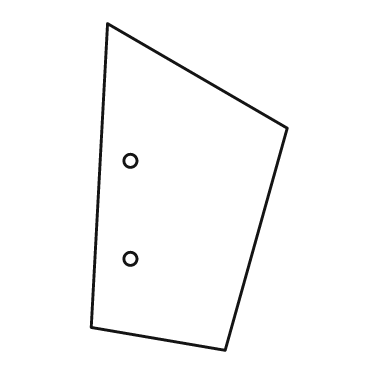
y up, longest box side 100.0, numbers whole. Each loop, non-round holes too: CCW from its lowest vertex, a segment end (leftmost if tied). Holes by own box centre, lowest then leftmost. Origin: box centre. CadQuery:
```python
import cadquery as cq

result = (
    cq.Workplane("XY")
    .moveTo(11.0, -50.0)
    .lineTo(30.0, 18.0)
    .lineTo(-25.0, 50.0)
    .lineTo(-30.0, -43.0)
    .close()
    .moveTo(-18.0, -22.0)
    .circle(2.0)
    .moveTo(-18.0, 8.0)
    .circle(2.0)
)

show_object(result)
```